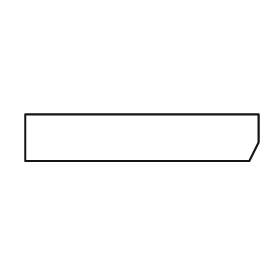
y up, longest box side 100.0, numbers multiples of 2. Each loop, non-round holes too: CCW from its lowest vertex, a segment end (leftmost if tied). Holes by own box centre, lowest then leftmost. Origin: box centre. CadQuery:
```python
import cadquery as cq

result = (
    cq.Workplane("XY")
    .moveTo(-50.0, -10.0)
    .lineTo(46.0, -10.0)
    .lineTo(50.0, -2.0)
    .lineTo(50.0, 10.0)
    .lineTo(-50.0, 10.0)
    .close()
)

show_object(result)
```